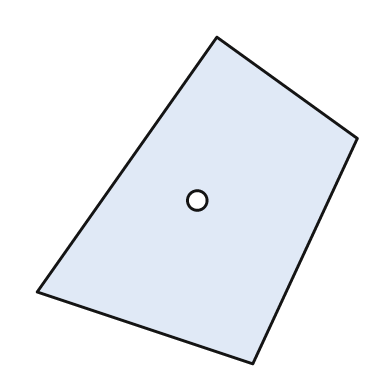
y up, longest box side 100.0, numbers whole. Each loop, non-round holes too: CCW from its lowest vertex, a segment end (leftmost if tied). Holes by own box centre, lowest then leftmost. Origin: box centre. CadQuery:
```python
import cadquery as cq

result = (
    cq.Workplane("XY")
    .moveTo(17.0, -50.0)
    .lineTo(49.0, 19.0)
    .lineTo(6.0, 50.0)
    .lineTo(-49.0, -28.0)
    .close()
    .moveTo(0.0, 0.0)
    .circle(3.0)
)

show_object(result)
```